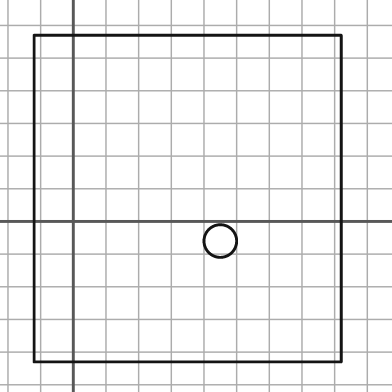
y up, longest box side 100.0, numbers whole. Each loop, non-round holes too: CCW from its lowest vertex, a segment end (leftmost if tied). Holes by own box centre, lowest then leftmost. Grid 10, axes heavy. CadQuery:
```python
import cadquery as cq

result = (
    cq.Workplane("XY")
    .moveTo(-12.0, -43.0)
    .lineTo(82.0, -43.0)
    .lineTo(82.0, 57.0)
    .lineTo(-12.0, 57.0)
    .close()
    .moveTo(45.0, -6.0)
    .circle(5.0)
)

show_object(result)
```